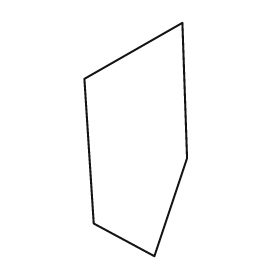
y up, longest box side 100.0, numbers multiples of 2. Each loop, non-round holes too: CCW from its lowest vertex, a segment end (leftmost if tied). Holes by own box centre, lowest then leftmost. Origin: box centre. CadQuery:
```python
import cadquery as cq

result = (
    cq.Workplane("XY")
    .moveTo(8.0, -50.0)
    .lineTo(22.0, -8.0)
    .lineTo(20.0, 50.0)
    .lineTo(-22.0, 26.0)
    .lineTo(-18.0, -36.0)
    .close()
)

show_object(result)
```